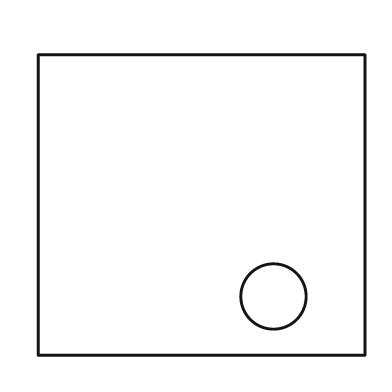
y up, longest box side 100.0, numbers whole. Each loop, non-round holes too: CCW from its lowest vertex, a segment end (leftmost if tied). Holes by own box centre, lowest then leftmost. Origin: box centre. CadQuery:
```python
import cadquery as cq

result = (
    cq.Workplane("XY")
    .moveTo(-50.0, -46.0)
    .lineTo(50.0, -46.0)
    .lineTo(50.0, 46.0)
    .lineTo(-50.0, 46.0)
    .close()
    .moveTo(22.0, -28.0)
    .circle(10.0)
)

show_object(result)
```